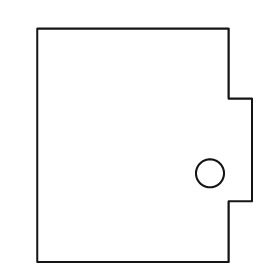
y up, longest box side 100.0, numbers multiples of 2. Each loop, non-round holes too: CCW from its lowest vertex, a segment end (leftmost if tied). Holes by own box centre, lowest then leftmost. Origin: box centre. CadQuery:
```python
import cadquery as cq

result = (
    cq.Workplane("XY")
    .moveTo(-46.0, -50.0)
    .lineTo(36.0, -50.0)
    .lineTo(36.0, -24.0)
    .lineTo(46.0, -24.0)
    .lineTo(46.0, 20.0)
    .lineTo(36.0, 20.0)
    .lineTo(36.0, 50.0)
    .lineTo(-46.0, 50.0)
    .close()
    .moveTo(28.0, -12.0)
    .circle(6.0)
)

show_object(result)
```